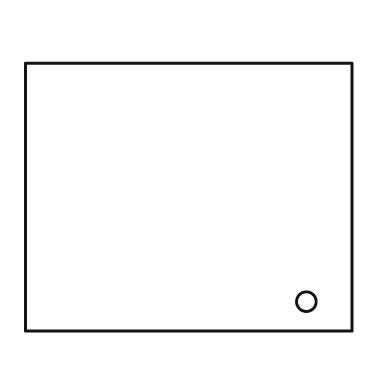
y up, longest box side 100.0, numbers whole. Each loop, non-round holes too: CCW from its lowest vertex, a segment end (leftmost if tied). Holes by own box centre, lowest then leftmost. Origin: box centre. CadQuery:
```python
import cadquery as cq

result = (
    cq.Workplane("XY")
    .moveTo(-50.0, -41.0)
    .lineTo(50.0, -41.0)
    .lineTo(50.0, 41.0)
    .lineTo(-50.0, 41.0)
    .close()
    .moveTo(36.0, -32.0)
    .circle(3.0)
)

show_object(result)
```